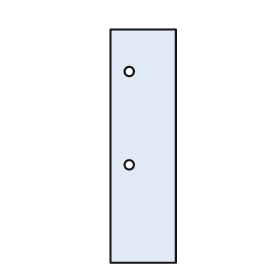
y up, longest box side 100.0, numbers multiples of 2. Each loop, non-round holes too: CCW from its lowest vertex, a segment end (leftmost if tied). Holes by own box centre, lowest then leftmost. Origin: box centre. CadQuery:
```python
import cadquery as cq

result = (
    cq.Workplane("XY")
    .moveTo(-14.0, -50.0)
    .lineTo(14.0, -50.0)
    .lineTo(14.0, 50.0)
    .lineTo(-14.0, 50.0)
    .close()
    .moveTo(-6.0, -8.0)
    .circle(2.0)
    .moveTo(-6.0, 32.0)
    .circle(2.0)
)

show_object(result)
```